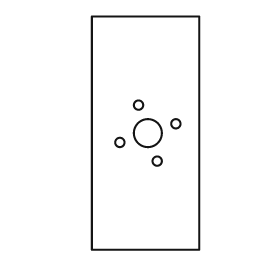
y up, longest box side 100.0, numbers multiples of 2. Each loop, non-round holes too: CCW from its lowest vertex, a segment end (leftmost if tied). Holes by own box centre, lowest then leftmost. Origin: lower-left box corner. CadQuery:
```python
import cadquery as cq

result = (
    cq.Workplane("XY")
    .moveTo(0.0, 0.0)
    .lineTo(46.0, 0.0)
    .lineTo(46.0, 100.0)
    .lineTo(0.0, 100.0)
    .close()
    .moveTo(28.0, 38.0)
    .circle(2.0)
    .moveTo(12.0, 46.0)
    .circle(2.0)
    .moveTo(24.0, 50.0)
    .circle(6.0)
    .moveTo(36.0, 54.0)
    .circle(2.0)
    .moveTo(20.0, 62.0)
    .circle(2.0)
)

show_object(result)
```